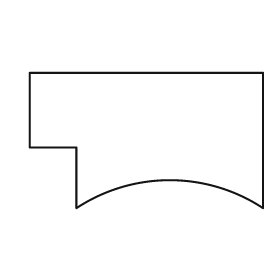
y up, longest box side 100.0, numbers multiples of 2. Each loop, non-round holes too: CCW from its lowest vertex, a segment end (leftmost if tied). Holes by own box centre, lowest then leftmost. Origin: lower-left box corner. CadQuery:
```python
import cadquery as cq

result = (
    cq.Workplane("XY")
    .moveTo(20.0, 0.0)
    .threePointArc((60.0, 12.0), (100.0, 0.0))
    .lineTo(100.0, 58.0)
    .lineTo(0.0, 58.0)
    .lineTo(0.0, 26.0)
    .lineTo(20.0, 26.0)
    .close()
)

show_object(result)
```